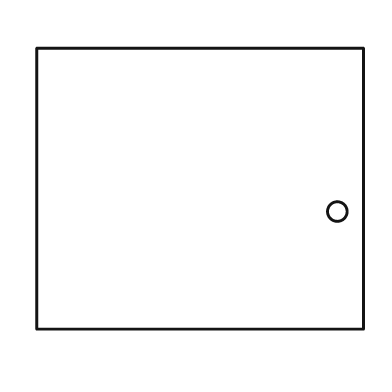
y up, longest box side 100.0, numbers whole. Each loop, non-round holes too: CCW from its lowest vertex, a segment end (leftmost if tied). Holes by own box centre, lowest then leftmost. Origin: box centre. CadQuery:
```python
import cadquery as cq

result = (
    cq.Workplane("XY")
    .moveTo(-50.0, -43.0)
    .lineTo(50.0, -43.0)
    .lineTo(50.0, 43.0)
    .lineTo(-50.0, 43.0)
    .close()
    .moveTo(42.0, -7.0)
    .circle(3.0)
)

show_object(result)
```